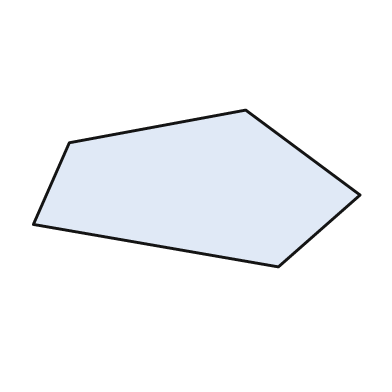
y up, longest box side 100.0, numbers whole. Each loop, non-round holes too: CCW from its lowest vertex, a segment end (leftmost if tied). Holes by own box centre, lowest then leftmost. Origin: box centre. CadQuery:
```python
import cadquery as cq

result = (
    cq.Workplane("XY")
    .moveTo(25.0, -24.0)
    .lineTo(50.0, -2.0)
    .lineTo(15.0, 24.0)
    .lineTo(-39.0, 14.0)
    .lineTo(-50.0, -11.0)
    .close()
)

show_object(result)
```